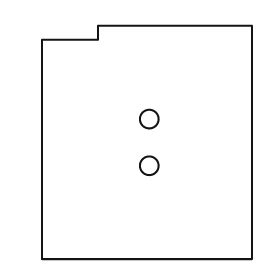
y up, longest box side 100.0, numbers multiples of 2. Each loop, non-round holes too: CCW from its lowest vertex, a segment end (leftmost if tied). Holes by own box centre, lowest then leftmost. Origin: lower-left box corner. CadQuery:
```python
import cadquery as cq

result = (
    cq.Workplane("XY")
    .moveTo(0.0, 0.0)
    .lineTo(90.0, 0.0)
    .lineTo(90.0, 100.0)
    .lineTo(24.0, 100.0)
    .lineTo(24.0, 94.0)
    .lineTo(0.0, 94.0)
    .close()
    .moveTo(46.0, 40.0)
    .circle(4.0)
    .moveTo(46.0, 60.0)
    .circle(4.0)
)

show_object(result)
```